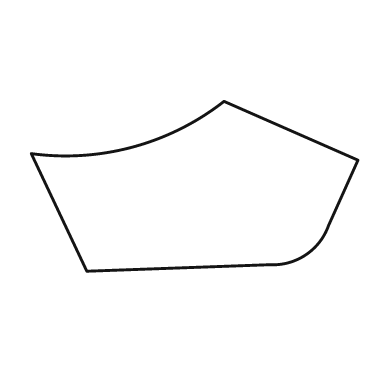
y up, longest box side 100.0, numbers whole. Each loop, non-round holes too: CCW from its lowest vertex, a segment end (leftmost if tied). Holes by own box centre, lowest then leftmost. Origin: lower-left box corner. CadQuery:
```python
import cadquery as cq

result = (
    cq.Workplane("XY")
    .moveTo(17.0, 0.0)
    .lineTo(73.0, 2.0)
    .threePointArc((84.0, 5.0), (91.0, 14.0))
    .lineTo(100.0, 34.0)
    .lineTo(59.0, 52.0)
    .threePointArc((31.0, 38.0), (0.0, 36.0))
    .close()
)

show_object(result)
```